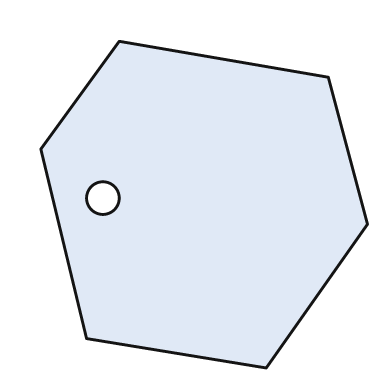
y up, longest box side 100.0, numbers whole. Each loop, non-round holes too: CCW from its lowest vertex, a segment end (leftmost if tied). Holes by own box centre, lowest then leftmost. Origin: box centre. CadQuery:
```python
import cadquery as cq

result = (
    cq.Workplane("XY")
    .moveTo(19.0, -50.0)
    .lineTo(50.0, -6.0)
    .lineTo(38.0, 39.0)
    .lineTo(-26.0, 50.0)
    .lineTo(-50.0, 17.0)
    .lineTo(-36.0, -41.0)
    .close()
    .moveTo(-31.0, 2.0)
    .circle(5.0)
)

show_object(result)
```